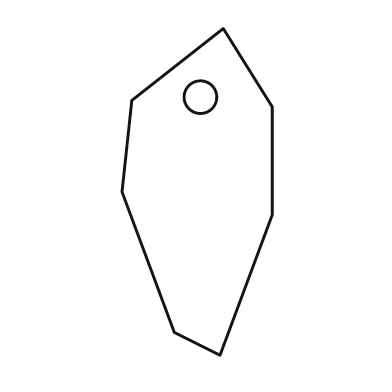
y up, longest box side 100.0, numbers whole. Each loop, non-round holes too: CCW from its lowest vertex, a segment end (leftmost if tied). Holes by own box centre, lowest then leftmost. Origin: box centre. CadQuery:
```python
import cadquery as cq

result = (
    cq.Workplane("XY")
    .moveTo(7.0, -50.0)
    .lineTo(23.0, -7.0)
    .lineTo(23.0, 26.0)
    .lineTo(8.0, 50.0)
    .lineTo(-20.0, 28.0)
    .lineTo(-23.0, 0.0)
    .lineTo(-7.0, -43.0)
    .close()
    .moveTo(1.0, 29.0)
    .circle(5.0)
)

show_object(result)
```